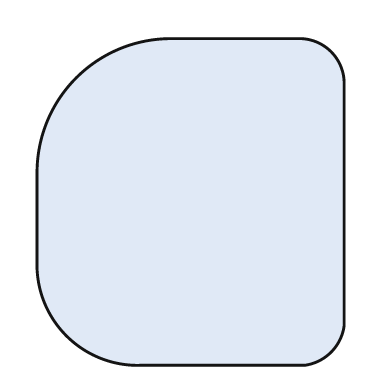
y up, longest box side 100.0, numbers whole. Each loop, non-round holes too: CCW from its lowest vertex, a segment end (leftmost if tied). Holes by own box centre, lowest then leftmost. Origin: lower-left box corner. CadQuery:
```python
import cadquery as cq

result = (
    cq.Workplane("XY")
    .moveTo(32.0, 0.0)
    .lineTo(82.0, 0.0)
    .threePointArc((90.0, 4.0), (94.0, 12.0))
    .lineTo(94.0, 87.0)
    .threePointArc((90.0, 96.0), (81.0, 100.0))
    .lineTo(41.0, 100.0)
    .threePointArc((12.0, 88.0), (0.0, 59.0))
    .lineTo(0.0, 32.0)
    .threePointArc((9.0, 9.0), (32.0, 0.0))
    .close()
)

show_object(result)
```